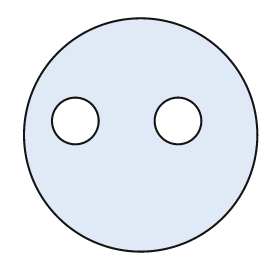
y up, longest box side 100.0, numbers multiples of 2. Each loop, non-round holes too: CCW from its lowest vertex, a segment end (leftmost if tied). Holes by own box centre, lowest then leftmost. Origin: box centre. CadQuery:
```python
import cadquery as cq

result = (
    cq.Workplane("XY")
    .moveTo(0.0, 0.0)
    .circle(50.0)
    .moveTo(-28.0, 6.0)
    .circle(10.0)
    .moveTo(16.0, 6.0)
    .circle(10.0)
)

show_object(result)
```